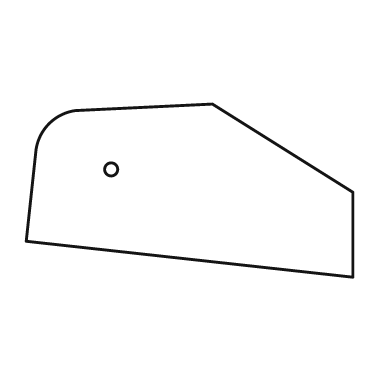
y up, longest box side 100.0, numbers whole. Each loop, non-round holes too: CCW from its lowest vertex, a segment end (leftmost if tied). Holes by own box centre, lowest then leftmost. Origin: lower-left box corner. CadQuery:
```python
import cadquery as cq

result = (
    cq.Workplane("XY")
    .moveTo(100.0, 0.0)
    .lineTo(100.0, 26.0)
    .lineTo(57.0, 53.0)
    .lineTo(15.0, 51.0)
    .threePointArc((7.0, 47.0), (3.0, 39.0))
    .lineTo(0.0, 11.0)
    .close()
    .moveTo(26.0, 33.0)
    .circle(2.0)
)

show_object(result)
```